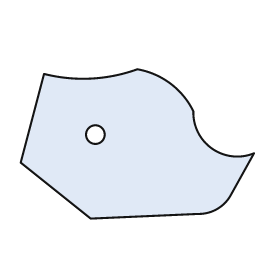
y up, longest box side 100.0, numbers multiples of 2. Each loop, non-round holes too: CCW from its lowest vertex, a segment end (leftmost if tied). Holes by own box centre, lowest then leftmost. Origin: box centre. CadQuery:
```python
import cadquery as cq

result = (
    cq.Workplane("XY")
    .moveTo(-20.0, -32.0)
    .lineTo(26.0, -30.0)
    .threePointArc((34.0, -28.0), (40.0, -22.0))
    .lineTo(50.0, -4.0)
    .threePointArc((32.0, -2.0), (24.0, 14.0))
    .threePointArc((14.0, 26.0), (0.0, 32.0))
    .threePointArc((-20.0, 28.0), (-40.0, 30.0))
    .lineTo(-50.0, -8.0)
    .close()
    .moveTo(-18.0, 4.0)
    .circle(4.0)
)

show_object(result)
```